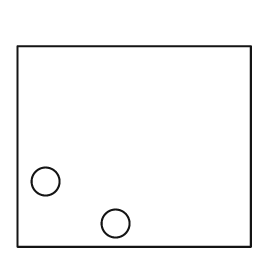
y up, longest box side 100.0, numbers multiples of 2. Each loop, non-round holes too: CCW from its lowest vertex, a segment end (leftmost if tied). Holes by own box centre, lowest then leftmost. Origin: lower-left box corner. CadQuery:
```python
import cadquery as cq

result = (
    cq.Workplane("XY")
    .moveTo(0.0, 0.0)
    .lineTo(100.0, 0.0)
    .lineTo(100.0, 86.0)
    .lineTo(0.0, 86.0)
    .close()
    .moveTo(42.0, 10.0)
    .circle(6.0)
    .moveTo(12.0, 28.0)
    .circle(6.0)
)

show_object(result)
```